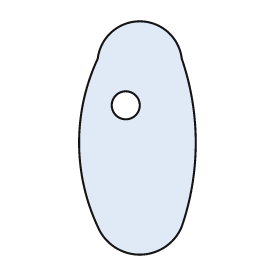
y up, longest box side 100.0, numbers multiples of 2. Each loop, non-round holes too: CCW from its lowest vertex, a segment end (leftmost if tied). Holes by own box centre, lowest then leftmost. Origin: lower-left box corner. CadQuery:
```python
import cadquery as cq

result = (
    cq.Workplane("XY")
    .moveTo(8.0, 12.0)
    .threePointArc((26.0, 0.0), (44.0, 12.0))
    .threePointArc((50.0, 48.0), (44.0, 84.0))
    .threePointArc((26.0, 100.0), (8.0, 84.0))
    .threePointArc((0.0, 48.0), (8.0, 12.0))
    .close()
    .moveTo(20.0, 64.0)
    .circle(6.0)
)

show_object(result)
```